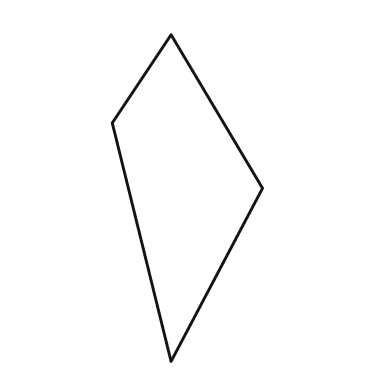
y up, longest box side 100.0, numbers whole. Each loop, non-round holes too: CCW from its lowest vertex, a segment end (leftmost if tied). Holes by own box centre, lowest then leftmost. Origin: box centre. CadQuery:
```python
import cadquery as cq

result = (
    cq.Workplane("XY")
    .moveTo(-5.0, -50.0)
    .lineTo(23.0, 3.0)
    .lineTo(-5.0, 50.0)
    .lineTo(-23.0, 23.0)
    .close()
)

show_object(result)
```